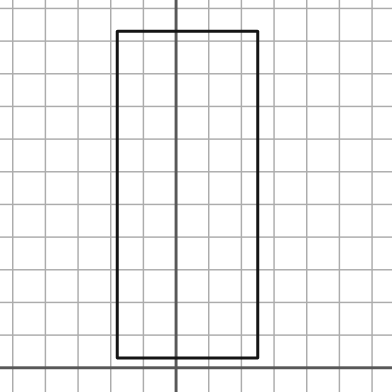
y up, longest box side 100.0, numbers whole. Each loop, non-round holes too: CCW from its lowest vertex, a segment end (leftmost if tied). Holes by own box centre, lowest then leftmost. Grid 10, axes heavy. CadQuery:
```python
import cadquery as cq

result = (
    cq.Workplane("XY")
    .moveTo(-18.0, 3.0)
    .lineTo(25.0, 3.0)
    .lineTo(25.0, 103.0)
    .lineTo(-18.0, 103.0)
    .close()
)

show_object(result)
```